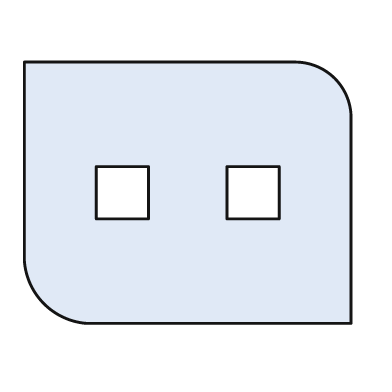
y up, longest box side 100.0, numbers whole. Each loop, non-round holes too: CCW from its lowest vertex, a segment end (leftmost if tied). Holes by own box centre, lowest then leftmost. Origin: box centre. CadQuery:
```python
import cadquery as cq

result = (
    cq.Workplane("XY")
    .moveTo(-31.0, -40.0)
    .lineTo(50.0, -40.0)
    .lineTo(50.0, 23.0)
    .threePointArc((45.0, 35.0), (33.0, 40.0))
    .lineTo(-50.0, 40.0)
    .lineTo(-50.0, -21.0)
    .threePointArc((-44.0, -34.0), (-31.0, -40.0))
    .close()
    .moveTo(-28.0, -8.0)
    .lineTo(-12.0, -8.0)
    .lineTo(-12.0, 8.0)
    .lineTo(-28.0, 8.0)
    .close()
    .moveTo(12.0, -8.0)
    .lineTo(28.0, -8.0)
    .lineTo(28.0, 8.0)
    .lineTo(12.0, 8.0)
    .close()
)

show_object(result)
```